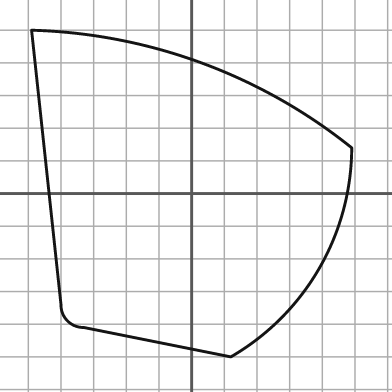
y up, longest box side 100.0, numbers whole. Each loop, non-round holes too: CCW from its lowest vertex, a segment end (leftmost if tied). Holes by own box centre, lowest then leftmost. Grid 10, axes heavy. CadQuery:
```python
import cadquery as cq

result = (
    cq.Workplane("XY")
    .moveTo(12.0, -50.0)
    .threePointArc((39.0, -23.0), (49.0, 14.0))
    .threePointArc((3.0, 40.0), (-49.0, 50.0))
    .lineTo(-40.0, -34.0)
    .threePointArc((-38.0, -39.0), (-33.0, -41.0))
    .close()
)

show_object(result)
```